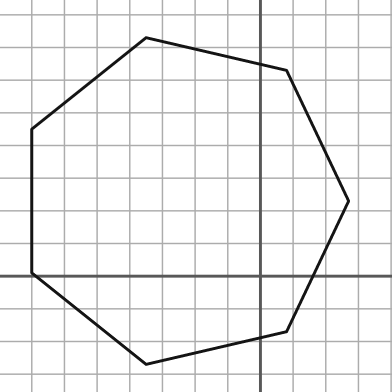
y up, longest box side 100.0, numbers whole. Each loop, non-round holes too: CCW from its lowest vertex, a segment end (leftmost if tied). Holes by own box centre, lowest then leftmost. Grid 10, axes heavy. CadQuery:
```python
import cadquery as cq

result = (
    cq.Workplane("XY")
    .moveTo(-35.0, -27.0)
    .lineTo(8.0, -17.0)
    .lineTo(27.0, 23.0)
    .lineTo(8.0, 63.0)
    .lineTo(-35.0, 73.0)
    .lineTo(-70.0, 45.0)
    .lineTo(-70.0, 1.0)
    .close()
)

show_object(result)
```